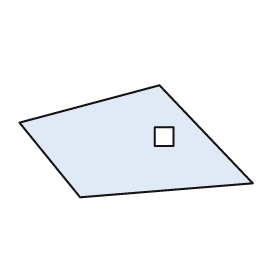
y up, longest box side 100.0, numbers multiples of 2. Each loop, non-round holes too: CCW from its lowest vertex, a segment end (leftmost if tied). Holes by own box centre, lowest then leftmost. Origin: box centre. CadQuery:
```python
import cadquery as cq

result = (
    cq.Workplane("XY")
    .moveTo(-24.0, -24.0)
    .lineTo(50.0, -18.0)
    .lineTo(10.0, 24.0)
    .lineTo(-50.0, 8.0)
    .close()
    .moveTo(8.0, -2.0)
    .lineTo(16.0, -2.0)
    .lineTo(16.0, 6.0)
    .lineTo(8.0, 6.0)
    .close()
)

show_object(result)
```